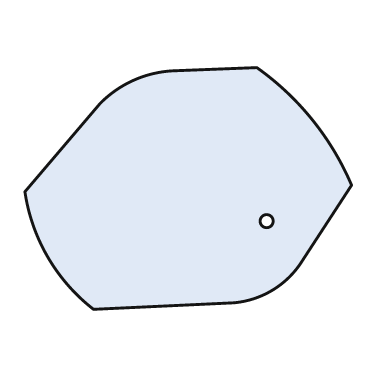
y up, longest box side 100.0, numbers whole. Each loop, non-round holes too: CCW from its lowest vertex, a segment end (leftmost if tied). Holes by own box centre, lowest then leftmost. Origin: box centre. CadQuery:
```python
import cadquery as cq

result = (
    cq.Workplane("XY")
    .moveTo(-29.0, -37.0)
    .lineTo(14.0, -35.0)
    .threePointArc((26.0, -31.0), (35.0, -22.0))
    .lineTo(50.0, 1.0)
    .threePointArc((38.0, 21.0), (21.0, 37.0))
    .lineTo(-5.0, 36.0)
    .threePointArc((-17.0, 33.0), (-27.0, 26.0))
    .lineTo(-50.0, -1.0)
    .threePointArc((-43.0, -21.0), (-29.0, -37.0))
    .close()
    .moveTo(24.0, -10.0)
    .circle(2.0)
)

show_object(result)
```